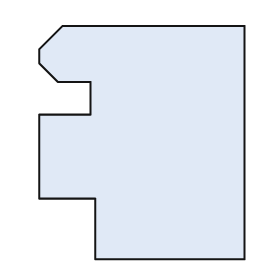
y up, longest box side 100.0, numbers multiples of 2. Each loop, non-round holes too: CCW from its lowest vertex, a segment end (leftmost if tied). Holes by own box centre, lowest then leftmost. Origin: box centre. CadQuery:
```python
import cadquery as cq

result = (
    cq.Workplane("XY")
    .moveTo(-20.0, -50.0)
    .lineTo(44.0, -50.0)
    .lineTo(44.0, 50.0)
    .lineTo(-34.0, 50.0)
    .lineTo(-44.0, 40.0)
    .lineTo(-44.0, 34.0)
    .lineTo(-36.0, 26.0)
    .lineTo(-22.0, 26.0)
    .lineTo(-22.0, 12.0)
    .lineTo(-44.0, 12.0)
    .lineTo(-44.0, -24.0)
    .lineTo(-20.0, -24.0)
    .close()
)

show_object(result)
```